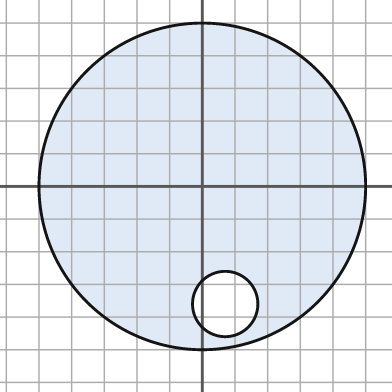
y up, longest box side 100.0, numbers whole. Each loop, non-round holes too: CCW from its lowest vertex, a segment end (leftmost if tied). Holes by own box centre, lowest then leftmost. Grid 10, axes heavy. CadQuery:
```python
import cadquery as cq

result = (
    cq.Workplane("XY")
    .moveTo(0.0, 0.0)
    .circle(50.0)
    .moveTo(7.0, -36.0)
    .circle(10.0)
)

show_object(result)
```